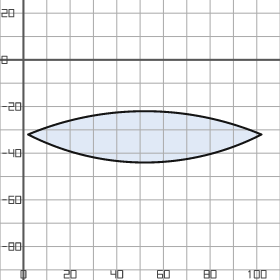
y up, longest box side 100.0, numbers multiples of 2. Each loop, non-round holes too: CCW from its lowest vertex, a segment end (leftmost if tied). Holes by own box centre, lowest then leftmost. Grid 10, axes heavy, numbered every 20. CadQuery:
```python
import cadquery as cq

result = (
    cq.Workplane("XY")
    .moveTo(2.0, -32.0)
    .threePointArc((52.0, -44.0), (102.0, -32.0))
    .threePointArc((52.0, -22.0), (2.0, -32.0))
    .close()
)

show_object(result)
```